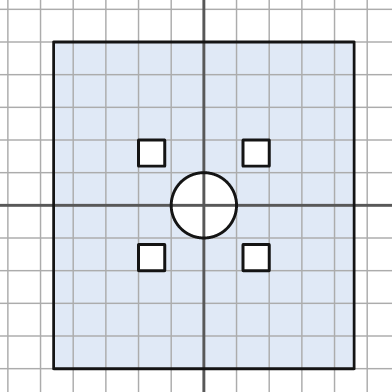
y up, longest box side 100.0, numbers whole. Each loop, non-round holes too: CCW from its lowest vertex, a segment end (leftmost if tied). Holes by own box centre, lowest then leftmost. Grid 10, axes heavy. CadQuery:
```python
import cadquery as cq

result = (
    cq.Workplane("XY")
    .moveTo(-46.0, -50.0)
    .lineTo(46.0, -50.0)
    .lineTo(46.0, 50.0)
    .lineTo(-46.0, 50.0)
    .close()
    .moveTo(-20.0, -20.0)
    .lineTo(-12.0, -20.0)
    .lineTo(-12.0, -12.0)
    .lineTo(-20.0, -12.0)
    .close()
    .moveTo(12.0, -20.0)
    .lineTo(20.0, -20.0)
    .lineTo(20.0, -12.0)
    .lineTo(12.0, -12.0)
    .close()
    .moveTo(0.0, 0.0)
    .circle(10.0)
    .moveTo(-20.0, 12.0)
    .lineTo(-12.0, 12.0)
    .lineTo(-12.0, 20.0)
    .lineTo(-20.0, 20.0)
    .close()
    .moveTo(12.0, 12.0)
    .lineTo(20.0, 12.0)
    .lineTo(20.0, 20.0)
    .lineTo(12.0, 20.0)
    .close()
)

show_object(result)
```